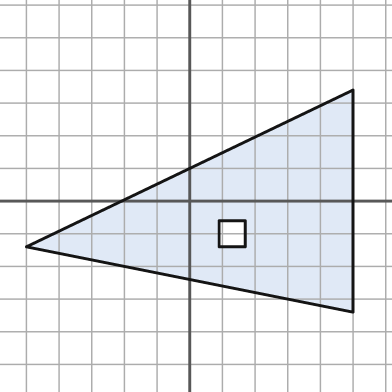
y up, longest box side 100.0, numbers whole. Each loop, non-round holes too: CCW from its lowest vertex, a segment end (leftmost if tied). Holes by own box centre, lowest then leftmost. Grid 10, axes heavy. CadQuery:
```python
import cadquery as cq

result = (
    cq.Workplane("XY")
    .moveTo(50.0, -34.0)
    .lineTo(50.0, 34.0)
    .lineTo(-50.0, -14.0)
    .close()
    .moveTo(9.0, -14.0)
    .lineTo(17.0, -14.0)
    .lineTo(17.0, -6.0)
    .lineTo(9.0, -6.0)
    .close()
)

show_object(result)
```